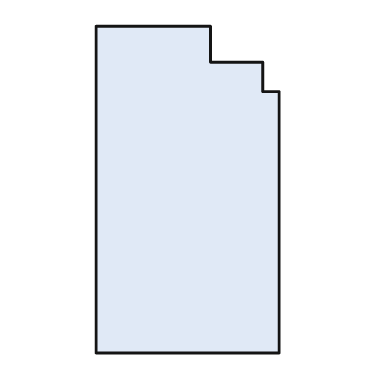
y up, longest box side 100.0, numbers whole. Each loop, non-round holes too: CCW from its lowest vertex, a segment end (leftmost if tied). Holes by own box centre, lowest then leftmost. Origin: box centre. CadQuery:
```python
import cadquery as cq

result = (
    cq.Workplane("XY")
    .moveTo(-28.0, -50.0)
    .lineTo(28.0, -50.0)
    .lineTo(28.0, 30.0)
    .lineTo(23.0, 30.0)
    .lineTo(23.0, 39.0)
    .lineTo(7.0, 39.0)
    .lineTo(7.0, 50.0)
    .lineTo(-28.0, 50.0)
    .close()
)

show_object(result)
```